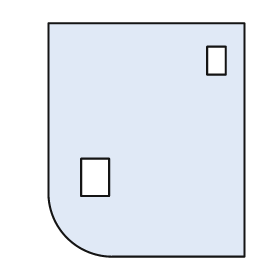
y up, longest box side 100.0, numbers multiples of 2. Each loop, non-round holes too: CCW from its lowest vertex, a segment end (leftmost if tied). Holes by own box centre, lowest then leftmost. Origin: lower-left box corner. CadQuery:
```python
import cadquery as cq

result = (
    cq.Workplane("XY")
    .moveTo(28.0, 0.0)
    .lineTo(84.0, 0.0)
    .lineTo(84.0, 100.0)
    .lineTo(0.0, 100.0)
    .lineTo(0.0, 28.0)
    .threePointArc((8.0, 8.0), (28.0, 0.0))
    .close()
    .moveTo(14.0, 26.0)
    .lineTo(26.0, 26.0)
    .lineTo(26.0, 42.0)
    .lineTo(14.0, 42.0)
    .close()
    .moveTo(68.0, 78.0)
    .lineTo(76.0, 78.0)
    .lineTo(76.0, 90.0)
    .lineTo(68.0, 90.0)
    .close()
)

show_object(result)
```